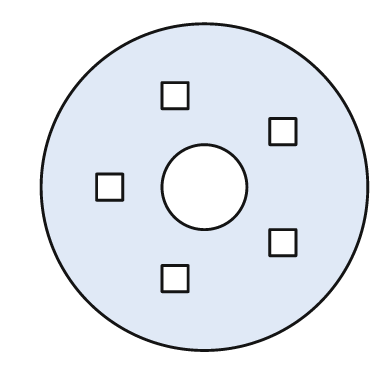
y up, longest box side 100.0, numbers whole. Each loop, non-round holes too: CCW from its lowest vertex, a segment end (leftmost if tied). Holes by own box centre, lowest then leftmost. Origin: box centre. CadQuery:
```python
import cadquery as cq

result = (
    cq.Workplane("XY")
    .moveTo(0.0, 0.0)
    .circle(50.0)
    .moveTo(-13.0, -32.0)
    .lineTo(-5.0, -32.0)
    .lineTo(-5.0, -24.0)
    .lineTo(-13.0, -24.0)
    .close()
    .moveTo(20.0, -21.0)
    .lineTo(28.0, -21.0)
    .lineTo(28.0, -13.0)
    .lineTo(20.0, -13.0)
    .close()
    .moveTo(-33.0, -4.0)
    .lineTo(-25.0, -4.0)
    .lineTo(-25.0, 4.0)
    .lineTo(-33.0, 4.0)
    .close()
    .moveTo(0.0, 0.0)
    .circle(13.0)
    .moveTo(20.0, 13.0)
    .lineTo(28.0, 13.0)
    .lineTo(28.0, 21.0)
    .lineTo(20.0, 21.0)
    .close()
    .moveTo(-13.0, 24.0)
    .lineTo(-5.0, 24.0)
    .lineTo(-5.0, 32.0)
    .lineTo(-13.0, 32.0)
    .close()
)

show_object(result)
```